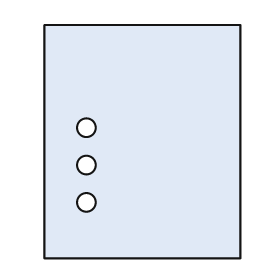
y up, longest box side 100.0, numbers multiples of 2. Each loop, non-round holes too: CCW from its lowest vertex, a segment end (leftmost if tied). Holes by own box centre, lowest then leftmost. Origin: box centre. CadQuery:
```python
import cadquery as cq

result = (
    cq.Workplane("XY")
    .moveTo(-42.0, -50.0)
    .lineTo(42.0, -50.0)
    .lineTo(42.0, 50.0)
    .lineTo(-42.0, 50.0)
    .close()
    .moveTo(-24.0, -26.0)
    .circle(4.0)
    .moveTo(-24.0, -10.0)
    .circle(4.0)
    .moveTo(-24.0, 6.0)
    .circle(4.0)
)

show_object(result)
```